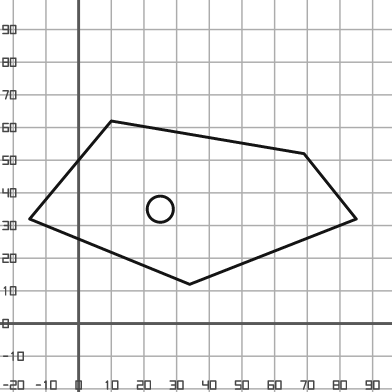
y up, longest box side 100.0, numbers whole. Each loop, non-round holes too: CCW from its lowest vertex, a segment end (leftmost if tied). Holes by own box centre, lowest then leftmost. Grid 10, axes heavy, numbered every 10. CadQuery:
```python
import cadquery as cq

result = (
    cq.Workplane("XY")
    .moveTo(34.0, 12.0)
    .lineTo(85.0, 32.0)
    .lineTo(69.0, 52.0)
    .lineTo(10.0, 62.0)
    .lineTo(-15.0, 32.0)
    .close()
    .moveTo(25.0, 35.0)
    .circle(4.0)
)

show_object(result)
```